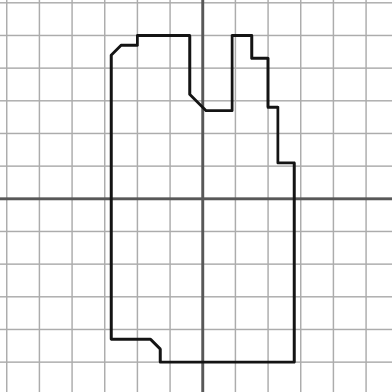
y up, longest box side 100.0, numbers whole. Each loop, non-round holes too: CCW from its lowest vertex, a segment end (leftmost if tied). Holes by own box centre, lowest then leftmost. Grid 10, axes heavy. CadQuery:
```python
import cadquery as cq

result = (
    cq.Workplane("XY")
    .moveTo(-13.0, -50.0)
    .lineTo(28.0, -50.0)
    .lineTo(28.0, 11.0)
    .lineTo(23.0, 11.0)
    .lineTo(23.0, 28.0)
    .lineTo(20.0, 28.0)
    .lineTo(20.0, 43.0)
    .lineTo(15.0, 43.0)
    .lineTo(15.0, 50.0)
    .lineTo(9.0, 50.0)
    .lineTo(9.0, 27.0)
    .lineTo(1.0, 27.0)
    .lineTo(-4.0, 32.0)
    .lineTo(-4.0, 50.0)
    .lineTo(-20.0, 50.0)
    .lineTo(-20.0, 47.0)
    .lineTo(-25.0, 47.0)
    .lineTo(-28.0, 44.0)
    .lineTo(-28.0, -43.0)
    .lineTo(-16.0, -43.0)
    .lineTo(-13.0, -46.0)
    .close()
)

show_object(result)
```